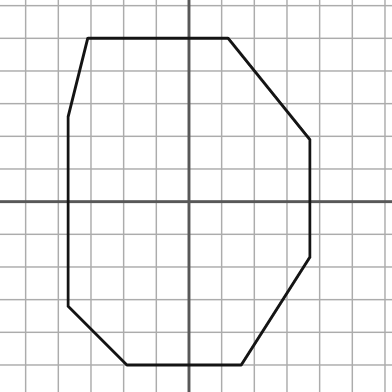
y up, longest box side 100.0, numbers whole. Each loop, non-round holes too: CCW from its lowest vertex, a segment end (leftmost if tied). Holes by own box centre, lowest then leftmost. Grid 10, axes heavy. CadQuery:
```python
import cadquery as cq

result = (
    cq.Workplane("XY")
    .moveTo(-19.0, -50.0)
    .lineTo(16.0, -50.0)
    .lineTo(37.0, -17.0)
    .lineTo(37.0, 19.0)
    .lineTo(12.0, 50.0)
    .lineTo(-31.0, 50.0)
    .lineTo(-37.0, 26.0)
    .lineTo(-37.0, -32.0)
    .close()
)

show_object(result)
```